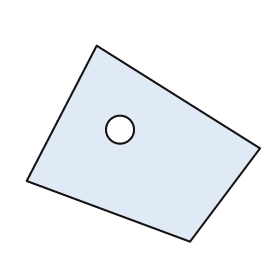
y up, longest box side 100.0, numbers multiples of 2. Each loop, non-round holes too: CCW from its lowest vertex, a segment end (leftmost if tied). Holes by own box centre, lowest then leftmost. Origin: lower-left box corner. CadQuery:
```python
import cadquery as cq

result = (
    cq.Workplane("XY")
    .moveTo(70.0, 0.0)
    .lineTo(100.0, 40.0)
    .lineTo(30.0, 84.0)
    .lineTo(0.0, 26.0)
    .close()
    .moveTo(40.0, 48.0)
    .circle(6.0)
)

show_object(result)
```